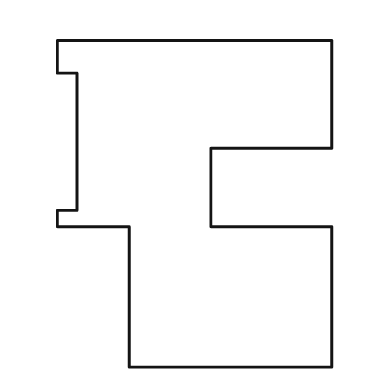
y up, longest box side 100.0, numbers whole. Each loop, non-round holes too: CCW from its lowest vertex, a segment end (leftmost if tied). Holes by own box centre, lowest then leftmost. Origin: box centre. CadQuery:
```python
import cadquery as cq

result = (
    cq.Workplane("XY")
    .moveTo(-20.0, -50.0)
    .lineTo(42.0, -50.0)
    .lineTo(42.0, -7.0)
    .lineTo(5.0, -7.0)
    .lineTo(5.0, 17.0)
    .lineTo(42.0, 17.0)
    .lineTo(42.0, 50.0)
    .lineTo(-42.0, 50.0)
    .lineTo(-42.0, 40.0)
    .lineTo(-36.0, 40.0)
    .lineTo(-36.0, -2.0)
    .lineTo(-42.0, -2.0)
    .lineTo(-42.0, -7.0)
    .lineTo(-20.0, -7.0)
    .close()
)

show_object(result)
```